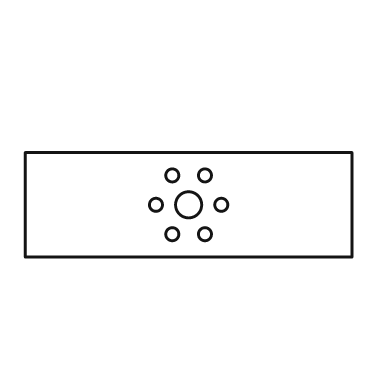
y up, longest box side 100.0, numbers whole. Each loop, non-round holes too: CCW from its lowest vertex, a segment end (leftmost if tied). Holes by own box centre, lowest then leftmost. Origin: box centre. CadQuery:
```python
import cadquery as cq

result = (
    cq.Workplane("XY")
    .moveTo(-50.0, -16.0)
    .lineTo(50.0, -16.0)
    .lineTo(50.0, 16.0)
    .lineTo(-50.0, 16.0)
    .close()
    .moveTo(-5.0, -9.0)
    .circle(2.0)
    .moveTo(5.0, -9.0)
    .circle(2.0)
    .moveTo(-10.0, 0.0)
    .circle(2.0)
    .moveTo(0.0, 0.0)
    .circle(4.0)
    .moveTo(10.0, 0.0)
    .circle(2.0)
    .moveTo(-5.0, 9.0)
    .circle(2.0)
    .moveTo(5.0, 9.0)
    .circle(2.0)
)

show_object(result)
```